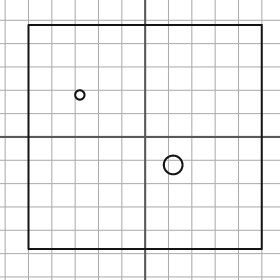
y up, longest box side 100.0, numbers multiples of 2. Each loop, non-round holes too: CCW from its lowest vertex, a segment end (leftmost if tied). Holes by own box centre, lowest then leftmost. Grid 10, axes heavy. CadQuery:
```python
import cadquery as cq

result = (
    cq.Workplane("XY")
    .moveTo(-50.0, -48.0)
    .lineTo(50.0, -48.0)
    .lineTo(50.0, 48.0)
    .lineTo(-50.0, 48.0)
    .close()
    .moveTo(12.0, -12.0)
    .circle(4.0)
    .moveTo(-28.0, 18.0)
    .circle(2.0)
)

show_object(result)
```